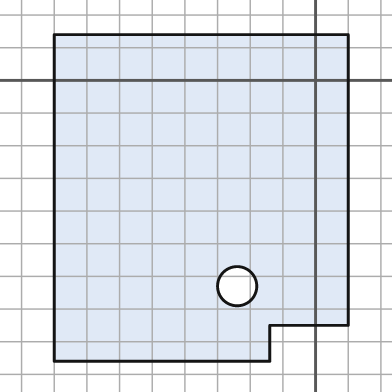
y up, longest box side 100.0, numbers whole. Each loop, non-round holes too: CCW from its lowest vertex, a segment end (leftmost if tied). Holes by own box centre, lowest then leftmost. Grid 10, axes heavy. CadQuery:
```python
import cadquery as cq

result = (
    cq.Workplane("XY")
    .moveTo(-80.0, -86.0)
    .lineTo(-14.0, -86.0)
    .lineTo(-14.0, -75.0)
    .lineTo(10.0, -75.0)
    .lineTo(10.0, 14.0)
    .lineTo(-80.0, 14.0)
    .close()
    .moveTo(-24.0, -63.0)
    .circle(6.0)
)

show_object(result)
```